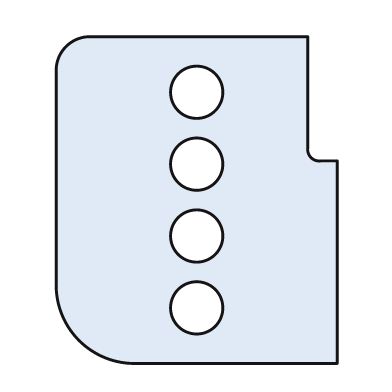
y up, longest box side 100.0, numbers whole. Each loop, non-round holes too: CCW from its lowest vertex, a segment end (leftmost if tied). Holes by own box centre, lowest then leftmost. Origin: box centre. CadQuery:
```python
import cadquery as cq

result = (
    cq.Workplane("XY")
    .moveTo(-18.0, -50.0)
    .lineTo(43.0, -50.0)
    .lineTo(43.0, 12.0)
    .lineTo(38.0, 12.0)
    .threePointArc((35.0, 13.0), (34.0, 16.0))
    .lineTo(34.0, 50.0)
    .lineTo(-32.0, 50.0)
    .threePointArc((-40.0, 47.0), (-43.0, 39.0))
    .lineTo(-43.0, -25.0)
    .threePointArc((-36.0, -43.0), (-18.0, -50.0))
    .close()
    .moveTo(0.0, -33.0)
    .circle(8.0)
    .moveTo(0.0, -11.0)
    .circle(8.0)
    .moveTo(0.0, 11.0)
    .circle(8.0)
    .moveTo(0.0, 33.0)
    .circle(8.0)
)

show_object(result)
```